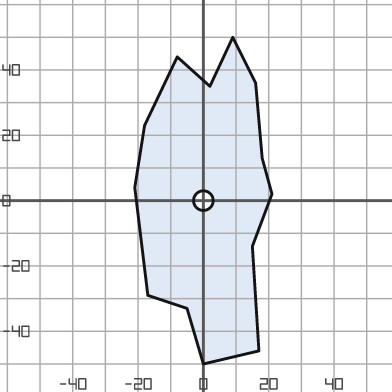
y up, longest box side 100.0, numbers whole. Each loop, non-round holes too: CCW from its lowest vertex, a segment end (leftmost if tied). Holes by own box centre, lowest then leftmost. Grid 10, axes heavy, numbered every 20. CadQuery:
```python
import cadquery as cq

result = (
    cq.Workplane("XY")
    .moveTo(0.0, -50.0)
    .lineTo(17.0, -46.0)
    .lineTo(15.0, -14.0)
    .lineTo(21.0, 2.0)
    .lineTo(18.0, 13.0)
    .lineTo(16.0, 36.0)
    .lineTo(9.0, 50.0)
    .lineTo(2.0, 35.0)
    .lineTo(-8.0, 44.0)
    .lineTo(-18.0, 23.0)
    .lineTo(-21.0, 4.0)
    .lineTo(-17.0, -29.0)
    .lineTo(-5.0, -33.0)
    .close()
    .moveTo(0.0, 0.0)
    .circle(3.0)
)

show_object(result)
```